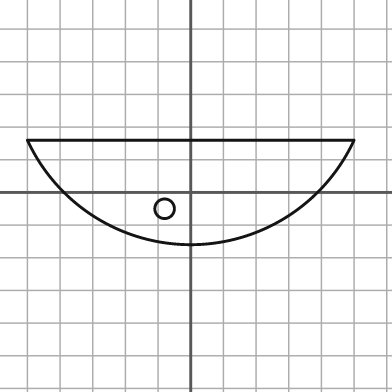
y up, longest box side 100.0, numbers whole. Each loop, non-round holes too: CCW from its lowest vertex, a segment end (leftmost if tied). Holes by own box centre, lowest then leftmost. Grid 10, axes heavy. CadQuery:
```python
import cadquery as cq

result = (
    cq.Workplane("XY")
    .moveTo(-50.0, 16.0)
    .threePointArc((0.0, -16.0), (50.0, 16.0))
    .close()
    .moveTo(-8.0, -5.0)
    .circle(3.0)
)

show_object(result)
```